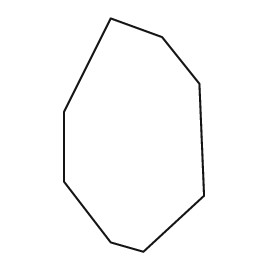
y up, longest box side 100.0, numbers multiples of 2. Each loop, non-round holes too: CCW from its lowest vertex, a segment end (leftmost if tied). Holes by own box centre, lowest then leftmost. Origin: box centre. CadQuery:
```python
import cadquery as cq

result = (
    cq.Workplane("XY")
    .moveTo(4.0, -50.0)
    .lineTo(30.0, -26.0)
    .lineTo(28.0, 22.0)
    .lineTo(12.0, 42.0)
    .lineTo(-10.0, 50.0)
    .lineTo(-30.0, 10.0)
    .lineTo(-30.0, -20.0)
    .lineTo(-10.0, -46.0)
    .close()
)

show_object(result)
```